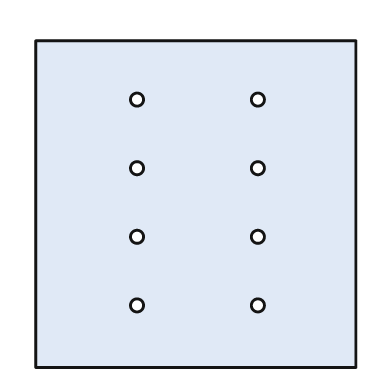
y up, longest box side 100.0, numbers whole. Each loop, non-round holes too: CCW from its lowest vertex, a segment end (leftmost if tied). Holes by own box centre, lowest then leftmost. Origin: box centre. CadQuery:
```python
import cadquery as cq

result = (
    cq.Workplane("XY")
    .moveTo(-49.0, -50.0)
    .lineTo(49.0, -50.0)
    .lineTo(49.0, 50.0)
    .lineTo(-49.0, 50.0)
    .close()
    .moveTo(-18.0, -31.0)
    .circle(2.0)
    .moveTo(19.0, -31.0)
    .circle(2.0)
    .moveTo(-18.0, -10.0)
    .circle(2.0)
    .moveTo(19.0, -10.0)
    .circle(2.0)
    .moveTo(-18.0, 11.0)
    .circle(2.0)
    .moveTo(19.0, 11.0)
    .circle(2.0)
    .moveTo(-18.0, 32.0)
    .circle(2.0)
    .moveTo(19.0, 32.0)
    .circle(2.0)
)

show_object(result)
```